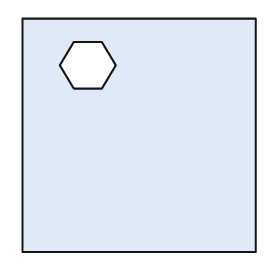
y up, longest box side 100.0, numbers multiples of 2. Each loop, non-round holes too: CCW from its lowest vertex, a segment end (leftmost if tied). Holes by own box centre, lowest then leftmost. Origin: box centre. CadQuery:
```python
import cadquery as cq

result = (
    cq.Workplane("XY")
    .moveTo(-50.0, -50.0)
    .lineTo(50.0, -50.0)
    .lineTo(50.0, 50.0)
    .lineTo(-50.0, 50.0)
    .close()
    .moveTo(-28.0, 20.0)
    .lineTo(-16.0, 20.0)
    .lineTo(-10.0, 30.0)
    .lineTo(-16.0, 40.0)
    .lineTo(-28.0, 40.0)
    .lineTo(-34.0, 30.0)
    .close()
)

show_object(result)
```